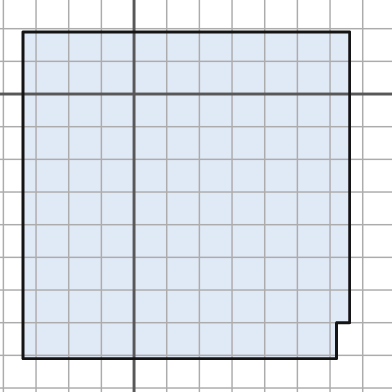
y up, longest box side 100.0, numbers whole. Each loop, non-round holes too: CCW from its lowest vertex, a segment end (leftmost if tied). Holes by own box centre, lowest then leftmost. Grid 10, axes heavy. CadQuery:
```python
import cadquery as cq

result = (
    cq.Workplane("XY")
    .moveTo(-34.0, -81.0)
    .lineTo(62.0, -81.0)
    .lineTo(62.0, -70.0)
    .lineTo(66.0, -70.0)
    .lineTo(66.0, 19.0)
    .lineTo(-34.0, 19.0)
    .close()
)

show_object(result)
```